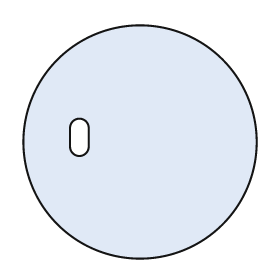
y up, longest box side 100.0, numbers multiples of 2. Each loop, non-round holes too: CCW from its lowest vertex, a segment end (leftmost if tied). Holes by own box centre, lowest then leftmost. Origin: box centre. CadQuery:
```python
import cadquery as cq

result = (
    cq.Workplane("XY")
    .moveTo(0.0, 0.0)
    .circle(50.0)
    .moveTo(-30.0, -2.0)
    .threePointArc((-26.0, -6.0), (-22.0, -2.0))
    .lineTo(-22.0, 6.0)
    .threePointArc((-26.0, 10.0), (-30.0, 6.0))
    .close()
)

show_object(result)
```